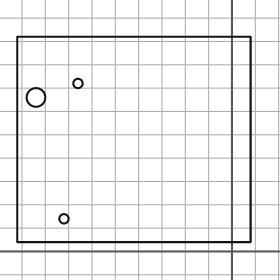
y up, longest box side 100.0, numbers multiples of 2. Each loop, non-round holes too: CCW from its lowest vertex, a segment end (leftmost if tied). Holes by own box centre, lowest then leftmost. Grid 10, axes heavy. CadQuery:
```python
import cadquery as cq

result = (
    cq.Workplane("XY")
    .moveTo(-92.0, 4.0)
    .lineTo(8.0, 4.0)
    .lineTo(8.0, 92.0)
    .lineTo(-92.0, 92.0)
    .close()
    .moveTo(-72.0, 14.0)
    .circle(2.0)
    .moveTo(-84.0, 66.0)
    .circle(4.0)
    .moveTo(-66.0, 72.0)
    .circle(2.0)
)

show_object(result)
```